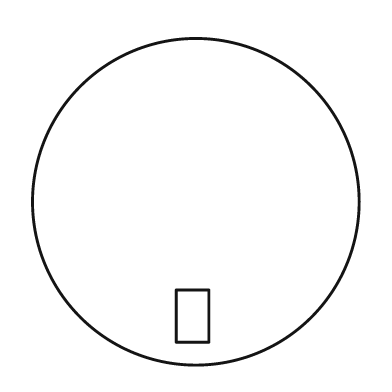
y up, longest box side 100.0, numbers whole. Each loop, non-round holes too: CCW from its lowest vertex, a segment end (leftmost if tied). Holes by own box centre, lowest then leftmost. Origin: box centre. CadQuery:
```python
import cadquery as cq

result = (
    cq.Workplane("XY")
    .moveTo(0.0, 0.0)
    .circle(50.0)
    .moveTo(-6.0, -43.0)
    .lineTo(4.0, -43.0)
    .lineTo(4.0, -27.0)
    .lineTo(-6.0, -27.0)
    .close()
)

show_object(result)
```